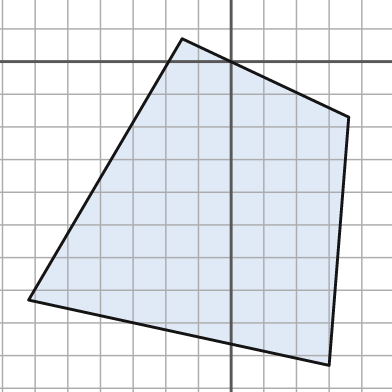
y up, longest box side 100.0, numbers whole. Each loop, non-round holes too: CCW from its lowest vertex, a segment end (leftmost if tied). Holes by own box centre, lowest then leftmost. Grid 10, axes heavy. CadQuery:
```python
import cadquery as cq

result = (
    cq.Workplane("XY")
    .moveTo(30.0, -93.0)
    .lineTo(36.0, -17.0)
    .lineTo(-15.0, 7.0)
    .lineTo(-62.0, -73.0)
    .close()
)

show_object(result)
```